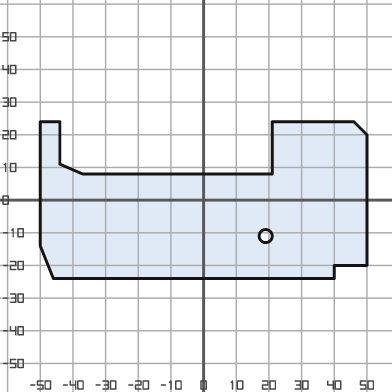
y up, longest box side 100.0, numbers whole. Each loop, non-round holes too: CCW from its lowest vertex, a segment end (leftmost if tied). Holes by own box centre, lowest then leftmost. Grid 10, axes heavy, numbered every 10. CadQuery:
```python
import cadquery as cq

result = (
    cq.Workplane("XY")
    .moveTo(-46.0, -24.0)
    .lineTo(40.0, -24.0)
    .lineTo(40.0, -20.0)
    .lineTo(50.0, -20.0)
    .lineTo(50.0, 20.0)
    .lineTo(46.0, 24.0)
    .lineTo(21.0, 24.0)
    .lineTo(21.0, 8.0)
    .lineTo(-37.0, 8.0)
    .lineTo(-44.0, 11.0)
    .lineTo(-44.0, 24.0)
    .lineTo(-50.0, 24.0)
    .lineTo(-50.0, -14.0)
    .close()
    .moveTo(19.0, -11.0)
    .circle(2.0)
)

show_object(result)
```